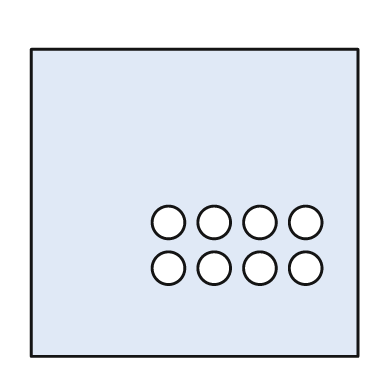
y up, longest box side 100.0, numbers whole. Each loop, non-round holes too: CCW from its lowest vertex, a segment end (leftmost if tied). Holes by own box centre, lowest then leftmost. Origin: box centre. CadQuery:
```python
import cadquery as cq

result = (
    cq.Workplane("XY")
    .moveTo(-50.0, -47.0)
    .lineTo(50.0, -47.0)
    .lineTo(50.0, 47.0)
    .lineTo(-50.0, 47.0)
    .close()
    .moveTo(-8.0, -20.0)
    .circle(5.0)
    .moveTo(6.0, -20.0)
    .circle(5.0)
    .moveTo(20.0, -20.0)
    .circle(5.0)
    .moveTo(34.0, -20.0)
    .circle(5.0)
    .moveTo(-8.0, -6.0)
    .circle(5.0)
    .moveTo(6.0, -6.0)
    .circle(5.0)
    .moveTo(20.0, -6.0)
    .circle(5.0)
    .moveTo(34.0, -6.0)
    .circle(5.0)
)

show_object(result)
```